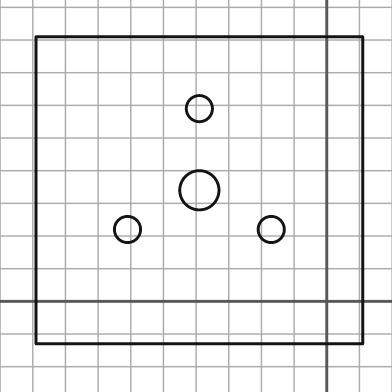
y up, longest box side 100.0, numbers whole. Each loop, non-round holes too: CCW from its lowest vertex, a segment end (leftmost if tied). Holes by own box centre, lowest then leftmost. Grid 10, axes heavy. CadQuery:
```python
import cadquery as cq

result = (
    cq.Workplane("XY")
    .moveTo(-89.0, -13.0)
    .lineTo(11.0, -13.0)
    .lineTo(11.0, 81.0)
    .lineTo(-89.0, 81.0)
    .close()
    .moveTo(-61.0, 22.0)
    .circle(4.0)
    .moveTo(-17.0, 22.0)
    .circle(4.0)
    .moveTo(-39.0, 34.0)
    .circle(6.0)
    .moveTo(-39.0, 59.0)
    .circle(4.0)
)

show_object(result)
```